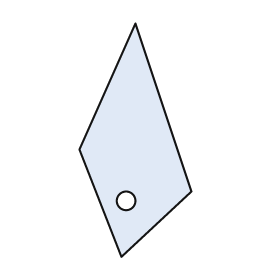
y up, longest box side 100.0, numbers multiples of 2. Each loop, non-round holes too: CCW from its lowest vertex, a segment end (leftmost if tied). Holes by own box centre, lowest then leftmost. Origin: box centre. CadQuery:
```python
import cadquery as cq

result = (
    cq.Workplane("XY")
    .moveTo(-6.0, -50.0)
    .lineTo(24.0, -22.0)
    .lineTo(0.0, 50.0)
    .lineTo(-24.0, -4.0)
    .close()
    .moveTo(-4.0, -26.0)
    .circle(4.0)
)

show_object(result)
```